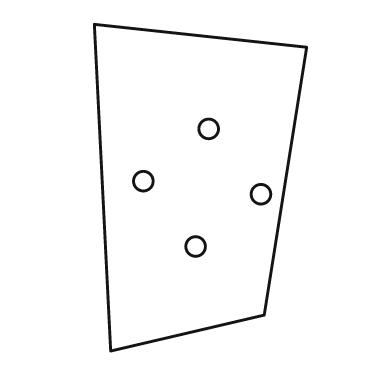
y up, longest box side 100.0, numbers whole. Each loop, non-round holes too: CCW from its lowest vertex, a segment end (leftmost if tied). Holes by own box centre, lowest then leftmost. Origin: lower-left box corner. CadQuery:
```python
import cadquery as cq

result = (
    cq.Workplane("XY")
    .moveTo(5.0, 0.0)
    .lineTo(52.0, 11.0)
    .lineTo(65.0, 93.0)
    .lineTo(0.0, 100.0)
    .close()
    .moveTo(31.0, 32.0)
    .circle(3.0)
    .moveTo(51.0, 48.0)
    .circle(3.0)
    .moveTo(15.0, 52.0)
    .circle(3.0)
    .moveTo(35.0, 68.0)
    .circle(3.0)
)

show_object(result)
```